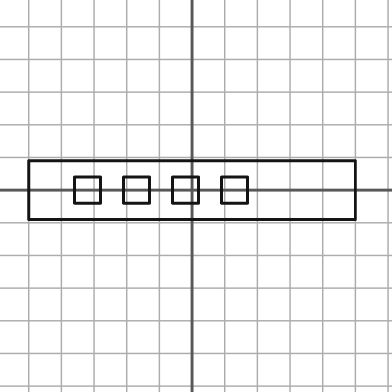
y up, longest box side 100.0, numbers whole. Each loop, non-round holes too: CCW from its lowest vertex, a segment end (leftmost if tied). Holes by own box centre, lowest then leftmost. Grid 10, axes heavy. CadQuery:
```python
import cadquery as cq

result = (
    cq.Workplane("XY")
    .moveTo(-50.0, -9.0)
    .lineTo(50.0, -9.0)
    .lineTo(50.0, 9.0)
    .lineTo(-50.0, 9.0)
    .close()
    .moveTo(-36.0, -4.0)
    .lineTo(-28.0, -4.0)
    .lineTo(-28.0, 4.0)
    .lineTo(-36.0, 4.0)
    .close()
    .moveTo(-21.0, -4.0)
    .lineTo(-13.0, -4.0)
    .lineTo(-13.0, 4.0)
    .lineTo(-21.0, 4.0)
    .close()
    .moveTo(-6.0, -4.0)
    .lineTo(2.0, -4.0)
    .lineTo(2.0, 4.0)
    .lineTo(-6.0, 4.0)
    .close()
    .moveTo(9.0, -4.0)
    .lineTo(17.0, -4.0)
    .lineTo(17.0, 4.0)
    .lineTo(9.0, 4.0)
    .close()
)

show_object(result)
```